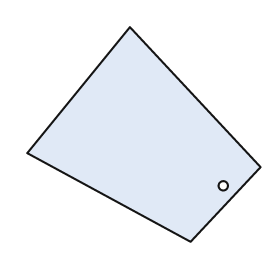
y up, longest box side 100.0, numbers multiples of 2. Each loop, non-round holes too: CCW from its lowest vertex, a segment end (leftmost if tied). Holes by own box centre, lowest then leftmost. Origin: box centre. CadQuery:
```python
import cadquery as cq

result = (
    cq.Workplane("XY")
    .moveTo(20.0, -46.0)
    .lineTo(50.0, -14.0)
    .lineTo(-6.0, 46.0)
    .lineTo(-50.0, -8.0)
    .close()
    .moveTo(34.0, -22.0)
    .circle(2.0)
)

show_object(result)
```